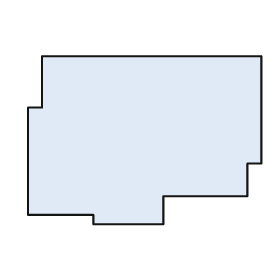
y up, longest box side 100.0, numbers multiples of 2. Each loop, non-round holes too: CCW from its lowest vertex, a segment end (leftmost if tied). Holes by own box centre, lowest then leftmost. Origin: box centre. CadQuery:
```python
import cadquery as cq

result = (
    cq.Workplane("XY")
    .moveTo(-22.0, -36.0)
    .lineTo(8.0, -36.0)
    .lineTo(8.0, -24.0)
    .lineTo(44.0, -24.0)
    .lineTo(44.0, -10.0)
    .lineTo(50.0, -10.0)
    .lineTo(50.0, 36.0)
    .lineTo(-44.0, 36.0)
    .lineTo(-44.0, 14.0)
    .lineTo(-50.0, 14.0)
    .lineTo(-50.0, -32.0)
    .lineTo(-22.0, -32.0)
    .close()
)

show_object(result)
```